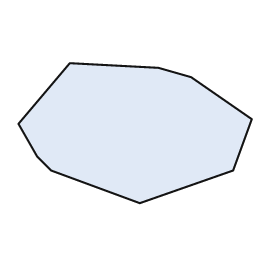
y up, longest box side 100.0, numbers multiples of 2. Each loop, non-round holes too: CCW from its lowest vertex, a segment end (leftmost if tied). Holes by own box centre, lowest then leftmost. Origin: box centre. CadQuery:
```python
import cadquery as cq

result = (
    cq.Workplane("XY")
    .moveTo(2.0, -30.0)
    .lineTo(42.0, -16.0)
    .lineTo(50.0, 6.0)
    .lineTo(24.0, 24.0)
    .lineTo(10.0, 28.0)
    .lineTo(-28.0, 30.0)
    .lineTo(-50.0, 4.0)
    .lineTo(-42.0, -10.0)
    .lineTo(-36.0, -16.0)
    .close()
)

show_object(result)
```